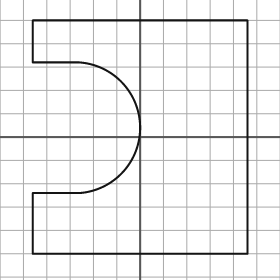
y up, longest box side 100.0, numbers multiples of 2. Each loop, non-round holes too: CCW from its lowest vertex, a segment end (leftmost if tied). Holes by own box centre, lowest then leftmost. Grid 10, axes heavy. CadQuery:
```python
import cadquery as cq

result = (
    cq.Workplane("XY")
    .moveTo(-46.0, -50.0)
    .lineTo(46.0, -50.0)
    .lineTo(46.0, 50.0)
    .lineTo(-46.0, 50.0)
    .lineTo(-46.0, 32.0)
    .lineTo(-26.0, 32.0)
    .threePointArc((0.0, 4.0), (-26.0, -24.0))
    .lineTo(-46.0, -24.0)
    .close()
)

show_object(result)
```